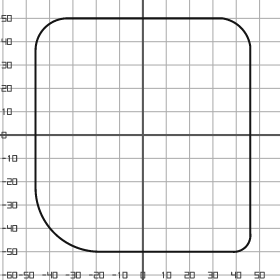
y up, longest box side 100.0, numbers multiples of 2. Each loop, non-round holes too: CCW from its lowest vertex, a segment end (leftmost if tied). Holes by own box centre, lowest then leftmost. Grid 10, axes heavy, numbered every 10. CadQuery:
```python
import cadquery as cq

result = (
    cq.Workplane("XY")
    .moveTo(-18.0, -50.0)
    .lineTo(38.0, -50.0)
    .threePointArc((44.0, -48.0), (46.0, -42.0))
    .lineTo(46.0, 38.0)
    .threePointArc((42.0, 46.0), (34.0, 50.0))
    .lineTo(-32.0, 50.0)
    .threePointArc((-42.0, 46.0), (-46.0, 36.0))
    .lineTo(-46.0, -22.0)
    .threePointArc((-38.0, -42.0), (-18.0, -50.0))
    .close()
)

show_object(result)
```